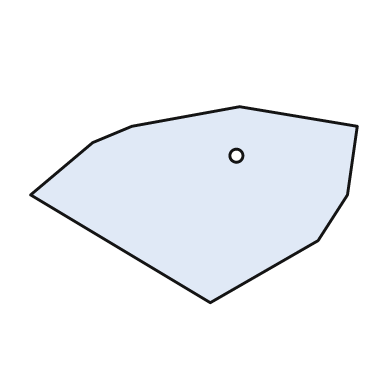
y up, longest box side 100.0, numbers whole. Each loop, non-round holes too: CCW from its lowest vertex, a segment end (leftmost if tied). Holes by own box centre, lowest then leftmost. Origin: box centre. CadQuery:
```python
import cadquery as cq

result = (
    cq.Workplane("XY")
    .moveTo(5.0, -30.0)
    .lineTo(38.0, -11.0)
    .lineTo(47.0, 3.0)
    .lineTo(50.0, 24.0)
    .lineTo(14.0, 30.0)
    .lineTo(-19.0, 24.0)
    .lineTo(-31.0, 19.0)
    .lineTo(-50.0, 3.0)
    .close()
    .moveTo(13.0, 15.0)
    .circle(2.0)
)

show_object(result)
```